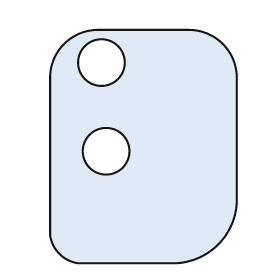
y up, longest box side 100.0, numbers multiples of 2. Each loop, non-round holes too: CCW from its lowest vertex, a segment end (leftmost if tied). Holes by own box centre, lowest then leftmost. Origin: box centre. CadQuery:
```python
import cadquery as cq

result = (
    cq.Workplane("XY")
    .moveTo(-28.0, -50.0)
    .lineTo(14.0, -50.0)
    .threePointArc((32.0, -42.0), (40.0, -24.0))
    .lineTo(40.0, 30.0)
    .threePointArc((34.0, 44.0), (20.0, 50.0))
    .lineTo(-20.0, 50.0)
    .threePointArc((-34.0, 44.0), (-40.0, 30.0))
    .lineTo(-40.0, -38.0)
    .threePointArc((-36.0, -46.0), (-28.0, -50.0))
    .close()
    .moveTo(-16.0, -2.0)
    .circle(10.0)
    .moveTo(-18.0, 36.0)
    .circle(10.0)
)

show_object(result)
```